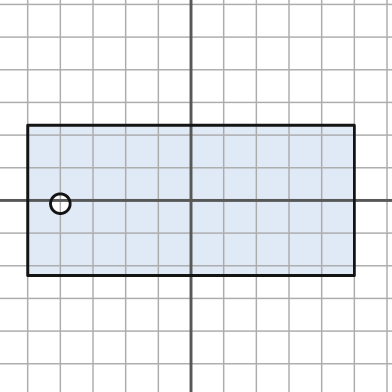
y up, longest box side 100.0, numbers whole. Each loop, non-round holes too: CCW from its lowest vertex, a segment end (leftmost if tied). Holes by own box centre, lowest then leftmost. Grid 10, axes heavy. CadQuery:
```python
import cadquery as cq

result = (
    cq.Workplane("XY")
    .moveTo(-50.0, -23.0)
    .lineTo(50.0, -23.0)
    .lineTo(50.0, 23.0)
    .lineTo(-50.0, 23.0)
    .close()
    .moveTo(-40.0, -1.0)
    .circle(3.0)
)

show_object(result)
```